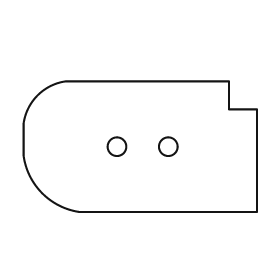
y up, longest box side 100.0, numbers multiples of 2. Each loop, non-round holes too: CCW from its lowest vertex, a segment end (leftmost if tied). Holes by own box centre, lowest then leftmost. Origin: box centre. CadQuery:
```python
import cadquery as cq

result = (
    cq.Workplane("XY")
    .moveTo(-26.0, -28.0)
    .lineTo(50.0, -28.0)
    .lineTo(50.0, 16.0)
    .lineTo(38.0, 16.0)
    .lineTo(38.0, 28.0)
    .lineTo(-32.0, 28.0)
    .threePointArc((-44.0, 22.0), (-50.0, 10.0))
    .lineTo(-50.0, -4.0)
    .threePointArc((-42.0, -20.0), (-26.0, -28.0))
    .close()
    .moveTo(-10.0, 0.0)
    .circle(4.0)
    .moveTo(12.0, 0.0)
    .circle(4.0)
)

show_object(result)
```